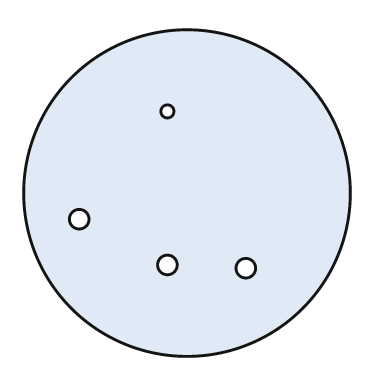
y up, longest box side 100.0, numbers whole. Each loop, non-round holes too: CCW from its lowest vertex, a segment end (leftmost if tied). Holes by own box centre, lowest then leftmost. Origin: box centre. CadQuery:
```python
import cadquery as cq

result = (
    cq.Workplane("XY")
    .moveTo(0.0, 0.0)
    .circle(50.0)
    .moveTo(18.0, -23.0)
    .circle(3.0)
    .moveTo(-6.0, -22.0)
    .circle(3.0)
    .moveTo(-33.0, -8.0)
    .circle(3.0)
    .moveTo(-6.0, 25.0)
    .circle(2.0)
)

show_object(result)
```